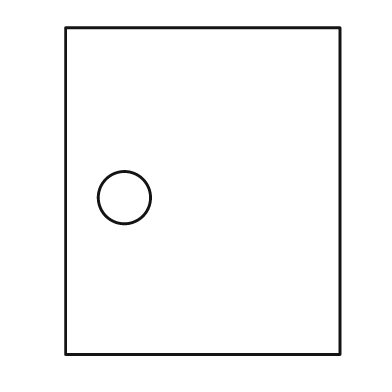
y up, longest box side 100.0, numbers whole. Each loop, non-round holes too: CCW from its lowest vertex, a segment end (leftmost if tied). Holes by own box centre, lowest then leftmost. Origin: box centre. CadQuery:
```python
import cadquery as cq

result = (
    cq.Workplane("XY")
    .moveTo(-42.0, -50.0)
    .lineTo(42.0, -50.0)
    .lineTo(42.0, 50.0)
    .lineTo(-42.0, 50.0)
    .close()
    .moveTo(-24.0, -2.0)
    .circle(8.0)
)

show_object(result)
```